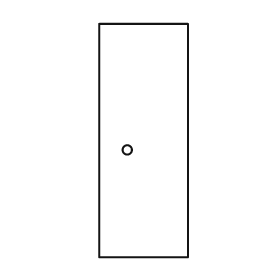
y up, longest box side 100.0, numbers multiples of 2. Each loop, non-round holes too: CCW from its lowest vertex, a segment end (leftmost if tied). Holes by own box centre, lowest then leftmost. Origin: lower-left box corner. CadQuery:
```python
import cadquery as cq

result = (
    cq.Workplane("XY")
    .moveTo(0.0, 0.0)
    .lineTo(38.0, 0.0)
    .lineTo(38.0, 100.0)
    .lineTo(0.0, 100.0)
    .close()
    .moveTo(12.0, 46.0)
    .circle(2.0)
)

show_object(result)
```